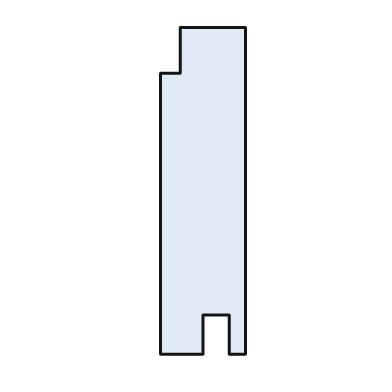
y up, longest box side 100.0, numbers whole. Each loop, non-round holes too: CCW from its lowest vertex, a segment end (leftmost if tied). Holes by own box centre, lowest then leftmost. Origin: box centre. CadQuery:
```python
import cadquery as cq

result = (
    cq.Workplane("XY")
    .moveTo(-13.0, -50.0)
    .lineTo(0.0, -50.0)
    .lineTo(0.0, -38.0)
    .lineTo(8.0, -38.0)
    .lineTo(8.0, -50.0)
    .lineTo(13.0, -50.0)
    .lineTo(13.0, 50.0)
    .lineTo(-7.0, 50.0)
    .lineTo(-7.0, 36.0)
    .lineTo(-13.0, 36.0)
    .close()
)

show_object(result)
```